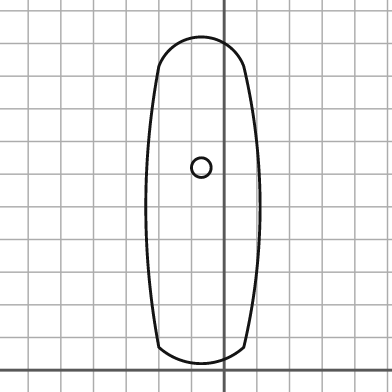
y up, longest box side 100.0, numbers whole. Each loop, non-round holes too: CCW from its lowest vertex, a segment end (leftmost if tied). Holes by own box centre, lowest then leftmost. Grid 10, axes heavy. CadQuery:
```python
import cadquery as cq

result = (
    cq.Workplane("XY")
    .moveTo(-20.0, 7.0)
    .threePointArc((-7.0, 2.0), (6.0, 7.0))
    .threePointArc((11.0, 50.0), (6.0, 93.0))
    .threePointArc((-7.0, 102.0), (-20.0, 93.0))
    .threePointArc((-24.0, 50.0), (-20.0, 7.0))
    .close()
    .moveTo(-7.0, 62.0)
    .circle(3.0)
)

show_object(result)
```